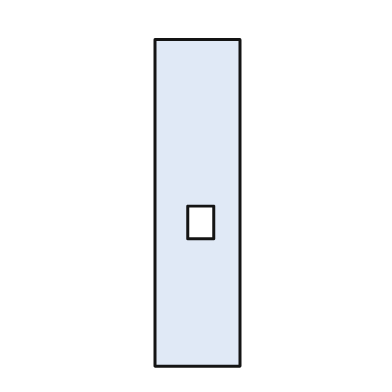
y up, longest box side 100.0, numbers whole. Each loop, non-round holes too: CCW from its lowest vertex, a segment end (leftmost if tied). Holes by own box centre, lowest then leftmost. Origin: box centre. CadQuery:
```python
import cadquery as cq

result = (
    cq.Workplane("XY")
    .moveTo(-13.0, -50.0)
    .lineTo(13.0, -50.0)
    .lineTo(13.0, 50.0)
    .lineTo(-13.0, 50.0)
    .close()
    .moveTo(-3.0, -11.0)
    .lineTo(5.0, -11.0)
    .lineTo(5.0, -1.0)
    .lineTo(-3.0, -1.0)
    .close()
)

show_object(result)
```